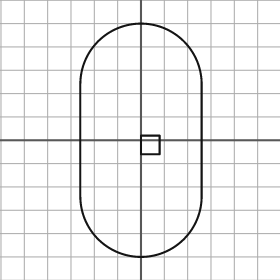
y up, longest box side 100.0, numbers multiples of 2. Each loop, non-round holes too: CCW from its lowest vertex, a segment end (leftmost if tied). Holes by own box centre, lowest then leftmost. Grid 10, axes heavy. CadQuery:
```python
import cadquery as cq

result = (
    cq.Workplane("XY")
    .moveTo(-26.0, -24.0)
    .threePointArc((0.0, -50.0), (26.0, -24.0))
    .lineTo(26.0, 24.0)
    .threePointArc((0.0, 50.0), (-26.0, 24.0))
    .close()
    .moveTo(0.0, -6.0)
    .lineTo(8.0, -6.0)
    .lineTo(8.0, 2.0)
    .lineTo(0.0, 2.0)
    .close()
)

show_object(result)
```